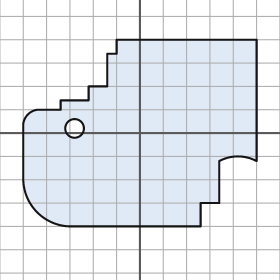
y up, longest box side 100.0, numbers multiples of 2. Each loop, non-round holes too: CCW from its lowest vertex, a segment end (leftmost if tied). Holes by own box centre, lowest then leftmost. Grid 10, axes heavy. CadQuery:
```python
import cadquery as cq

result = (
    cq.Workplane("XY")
    .moveTo(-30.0, -40.0)
    .lineTo(26.0, -40.0)
    .lineTo(26.0, -30.0)
    .lineTo(34.0, -30.0)
    .lineTo(34.0, -12.0)
    .threePointArc((42.0, -10.0), (50.0, -12.0))
    .lineTo(50.0, 40.0)
    .lineTo(-10.0, 40.0)
    .lineTo(-10.0, 34.0)
    .lineTo(-14.0, 34.0)
    .lineTo(-14.0, 20.0)
    .lineTo(-22.0, 20.0)
    .lineTo(-22.0, 14.0)
    .lineTo(-34.0, 14.0)
    .lineTo(-34.0, 10.0)
    .lineTo(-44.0, 10.0)
    .threePointArc((-48.0, 8.0), (-50.0, 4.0))
    .lineTo(-50.0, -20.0)
    .threePointArc((-44.0, -34.0), (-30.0, -40.0))
    .close()
    .moveTo(-28.0, 2.0)
    .circle(4.0)
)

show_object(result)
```